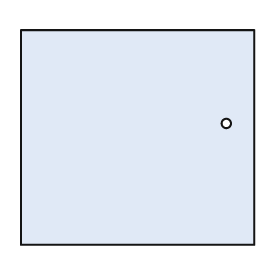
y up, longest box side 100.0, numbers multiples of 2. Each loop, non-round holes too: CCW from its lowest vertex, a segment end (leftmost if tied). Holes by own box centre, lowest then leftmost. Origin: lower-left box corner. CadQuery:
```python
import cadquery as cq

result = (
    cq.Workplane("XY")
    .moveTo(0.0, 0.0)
    .lineTo(100.0, 0.0)
    .lineTo(100.0, 92.0)
    .lineTo(0.0, 92.0)
    .close()
    .moveTo(88.0, 52.0)
    .circle(2.0)
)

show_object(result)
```